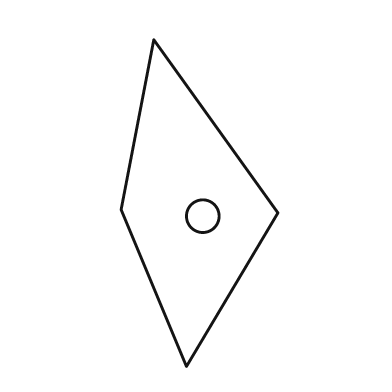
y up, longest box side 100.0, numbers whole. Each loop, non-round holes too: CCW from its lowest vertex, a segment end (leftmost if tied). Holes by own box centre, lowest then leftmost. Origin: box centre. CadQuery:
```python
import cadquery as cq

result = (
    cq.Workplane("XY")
    .moveTo(-4.0, -50.0)
    .lineTo(24.0, -3.0)
    .lineTo(-14.0, 50.0)
    .lineTo(-24.0, -2.0)
    .close()
    .moveTo(1.0, -4.0)
    .circle(5.0)
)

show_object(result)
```